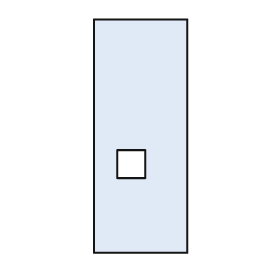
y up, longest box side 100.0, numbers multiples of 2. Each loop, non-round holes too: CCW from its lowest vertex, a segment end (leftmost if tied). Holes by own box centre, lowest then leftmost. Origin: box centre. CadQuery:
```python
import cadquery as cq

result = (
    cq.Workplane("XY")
    .moveTo(-20.0, -50.0)
    .lineTo(20.0, -50.0)
    .lineTo(20.0, 50.0)
    .lineTo(-20.0, 50.0)
    .close()
    .moveTo(-10.0, -18.0)
    .lineTo(2.0, -18.0)
    .lineTo(2.0, -6.0)
    .lineTo(-10.0, -6.0)
    .close()
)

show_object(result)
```